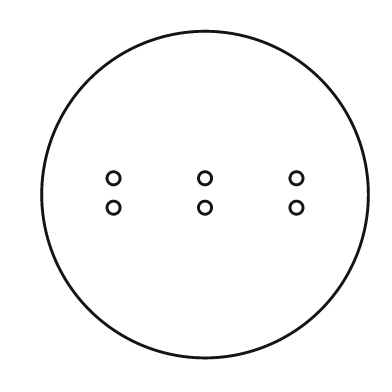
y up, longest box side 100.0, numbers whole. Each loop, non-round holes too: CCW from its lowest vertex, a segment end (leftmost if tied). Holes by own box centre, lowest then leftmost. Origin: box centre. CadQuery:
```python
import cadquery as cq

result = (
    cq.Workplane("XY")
    .moveTo(0.0, 0.0)
    .circle(50.0)
    .moveTo(-28.0, -4.0)
    .circle(2.0)
    .moveTo(0.0, -4.0)
    .circle(2.0)
    .moveTo(28.0, -4.0)
    .circle(2.0)
    .moveTo(-28.0, 5.0)
    .circle(2.0)
    .moveTo(0.0, 5.0)
    .circle(2.0)
    .moveTo(28.0, 5.0)
    .circle(2.0)
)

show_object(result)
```